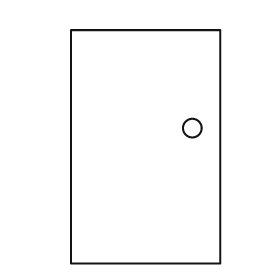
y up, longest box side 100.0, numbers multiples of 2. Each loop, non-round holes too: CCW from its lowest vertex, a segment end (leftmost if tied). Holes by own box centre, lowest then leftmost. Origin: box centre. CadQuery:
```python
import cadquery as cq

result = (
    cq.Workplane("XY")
    .moveTo(-32.0, -50.0)
    .lineTo(32.0, -50.0)
    .lineTo(32.0, 50.0)
    .lineTo(-32.0, 50.0)
    .close()
    .moveTo(20.0, 8.0)
    .circle(4.0)
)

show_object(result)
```